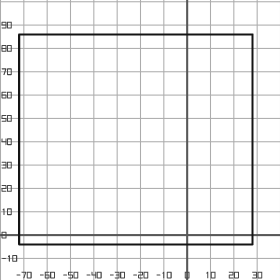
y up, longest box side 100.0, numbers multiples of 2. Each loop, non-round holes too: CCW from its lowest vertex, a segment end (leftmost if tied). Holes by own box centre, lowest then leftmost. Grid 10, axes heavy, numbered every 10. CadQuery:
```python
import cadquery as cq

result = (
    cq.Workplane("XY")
    .moveTo(-72.0, -4.0)
    .lineTo(28.0, -4.0)
    .lineTo(28.0, 86.0)
    .lineTo(-72.0, 86.0)
    .close()
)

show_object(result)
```